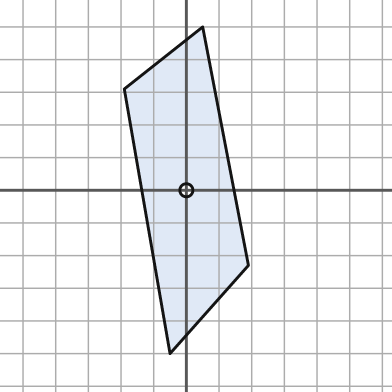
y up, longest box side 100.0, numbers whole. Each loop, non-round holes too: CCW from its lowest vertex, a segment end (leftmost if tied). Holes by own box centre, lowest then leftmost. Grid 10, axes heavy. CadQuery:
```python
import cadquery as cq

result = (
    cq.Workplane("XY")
    .moveTo(-5.0, -50.0)
    .lineTo(19.0, -23.0)
    .lineTo(5.0, 50.0)
    .lineTo(-19.0, 31.0)
    .close()
    .moveTo(0.0, 0.0)
    .circle(2.0)
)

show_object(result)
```